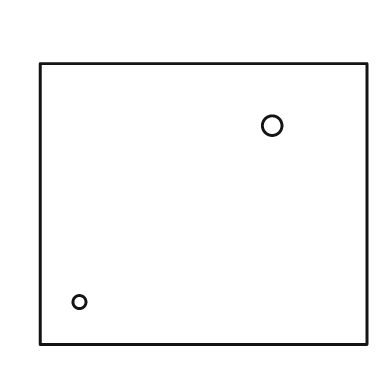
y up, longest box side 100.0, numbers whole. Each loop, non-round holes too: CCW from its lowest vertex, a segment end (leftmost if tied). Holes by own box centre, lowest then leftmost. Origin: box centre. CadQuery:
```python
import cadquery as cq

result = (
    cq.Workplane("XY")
    .moveTo(-50.0, -43.0)
    .lineTo(50.0, -43.0)
    .lineTo(50.0, 43.0)
    .lineTo(-50.0, 43.0)
    .close()
    .moveTo(-38.0, -30.0)
    .circle(2.0)
    .moveTo(21.0, 24.0)
    .circle(3.0)
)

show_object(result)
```